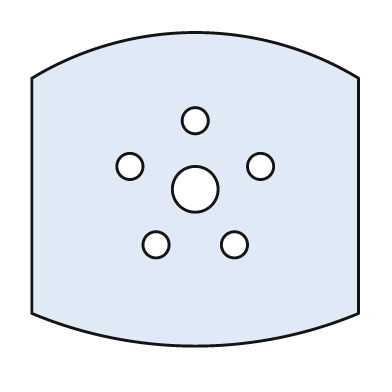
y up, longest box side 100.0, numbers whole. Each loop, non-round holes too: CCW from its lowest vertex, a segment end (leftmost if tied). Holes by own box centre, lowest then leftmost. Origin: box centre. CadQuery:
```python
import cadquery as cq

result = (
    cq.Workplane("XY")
    .moveTo(-50.0, -38.0)
    .threePointArc((0.0, -48.0), (50.0, -38.0))
    .lineTo(50.0, 34.0)
    .threePointArc((0.0, 48.0), (-50.0, 34.0))
    .close()
    .moveTo(-12.0, -17.0)
    .circle(4.0)
    .moveTo(12.0, -17.0)
    .circle(4.0)
    .moveTo(0.0, 0.0)
    .circle(7.0)
    .moveTo(-20.0, 7.0)
    .circle(4.0)
    .moveTo(20.0, 7.0)
    .circle(4.0)
    .moveTo(0.0, 21.0)
    .circle(4.0)
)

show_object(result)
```